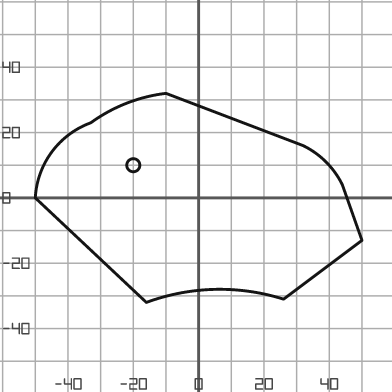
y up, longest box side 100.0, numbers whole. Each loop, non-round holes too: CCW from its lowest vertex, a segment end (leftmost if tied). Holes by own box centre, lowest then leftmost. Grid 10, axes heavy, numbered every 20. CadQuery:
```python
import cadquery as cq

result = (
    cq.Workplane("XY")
    .moveTo(-16.0, -32.0)
    .threePointArc((5.0, -28.0), (26.0, -31.0))
    .lineTo(50.0, -13.0)
    .lineTo(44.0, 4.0)
    .threePointArc((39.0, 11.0), (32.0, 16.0))
    .lineTo(-10.0, 32.0)
    .threePointArc((-22.0, 29.0), (-33.0, 23.0))
    .threePointArc((-45.0, 14.0), (-50.0, 0.0))
    .close()
    .moveTo(-20.0, 10.0)
    .circle(2.0)
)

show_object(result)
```